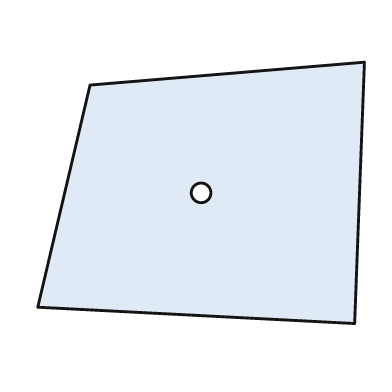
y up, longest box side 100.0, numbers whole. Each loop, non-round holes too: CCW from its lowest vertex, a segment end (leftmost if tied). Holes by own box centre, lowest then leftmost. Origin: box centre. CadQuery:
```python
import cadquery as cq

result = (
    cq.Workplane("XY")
    .moveTo(47.0, -40.0)
    .lineTo(50.0, 40.0)
    .lineTo(-34.0, 33.0)
    .lineTo(-50.0, -35.0)
    .close()
    .moveTo(0.0, 0.0)
    .circle(3.0)
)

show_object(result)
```